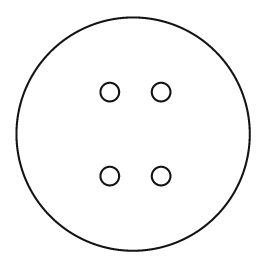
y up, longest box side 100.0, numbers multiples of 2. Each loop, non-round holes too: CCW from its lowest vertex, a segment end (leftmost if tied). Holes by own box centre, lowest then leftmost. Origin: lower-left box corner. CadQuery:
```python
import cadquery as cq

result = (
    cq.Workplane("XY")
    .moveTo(50.0, 50.0)
    .circle(50.0)
    .moveTo(40.0, 32.0)
    .circle(4.0)
    .moveTo(62.0, 32.0)
    .circle(4.0)
    .moveTo(40.0, 68.0)
    .circle(4.0)
    .moveTo(62.0, 68.0)
    .circle(4.0)
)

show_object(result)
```